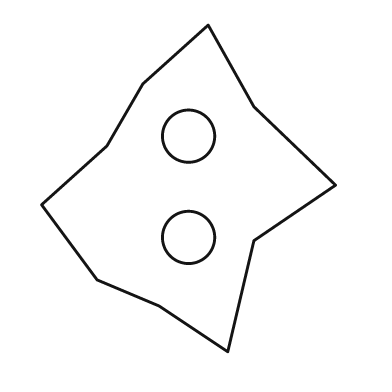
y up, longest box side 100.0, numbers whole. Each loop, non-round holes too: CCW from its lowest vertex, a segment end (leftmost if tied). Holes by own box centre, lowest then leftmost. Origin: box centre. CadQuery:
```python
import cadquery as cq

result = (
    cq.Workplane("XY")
    .moveTo(12.0, -50.0)
    .lineTo(20.0, -16.0)
    .lineTo(45.0, 1.0)
    .lineTo(20.0, 25.0)
    .lineTo(6.0, 50.0)
    .lineTo(-14.0, 32.0)
    .lineTo(-25.0, 13.0)
    .lineTo(-45.0, -5.0)
    .lineTo(-28.0, -28.0)
    .lineTo(-9.0, -36.0)
    .close()
    .moveTo(0.0, -15.0)
    .circle(8.0)
    .moveTo(0.0, 16.0)
    .circle(8.0)
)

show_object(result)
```